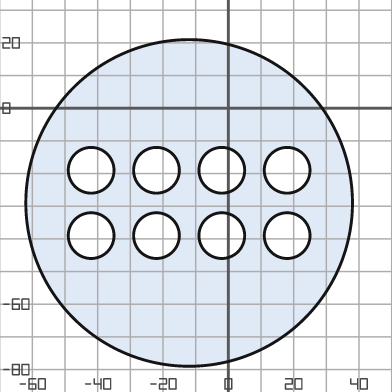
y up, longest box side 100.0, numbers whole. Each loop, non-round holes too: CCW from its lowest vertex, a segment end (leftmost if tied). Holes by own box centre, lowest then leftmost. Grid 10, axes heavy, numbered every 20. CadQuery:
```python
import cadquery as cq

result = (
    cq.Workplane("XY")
    .moveTo(-12.0, -29.0)
    .circle(50.0)
    .moveTo(-42.0, -39.0)
    .circle(7.0)
    .moveTo(-22.0, -39.0)
    .circle(7.0)
    .moveTo(-2.0, -39.0)
    .circle(7.0)
    .moveTo(18.0, -39.0)
    .circle(7.0)
    .moveTo(-42.0, -19.0)
    .circle(7.0)
    .moveTo(-22.0, -19.0)
    .circle(7.0)
    .moveTo(-2.0, -19.0)
    .circle(7.0)
    .moveTo(18.0, -19.0)
    .circle(7.0)
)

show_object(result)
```